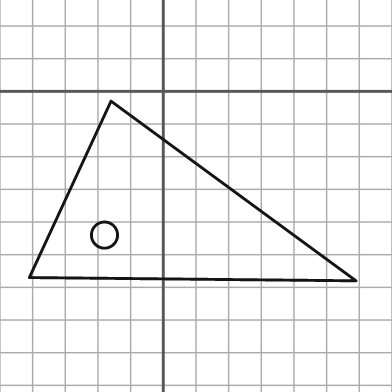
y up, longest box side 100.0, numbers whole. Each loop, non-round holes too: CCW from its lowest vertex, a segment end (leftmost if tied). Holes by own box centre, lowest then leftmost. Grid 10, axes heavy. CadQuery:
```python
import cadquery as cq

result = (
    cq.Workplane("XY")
    .moveTo(59.0, -58.0)
    .lineTo(-16.0, -3.0)
    .lineTo(-41.0, -57.0)
    .close()
    .moveTo(-18.0, -44.0)
    .circle(4.0)
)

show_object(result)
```